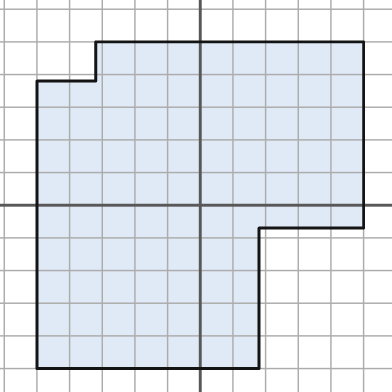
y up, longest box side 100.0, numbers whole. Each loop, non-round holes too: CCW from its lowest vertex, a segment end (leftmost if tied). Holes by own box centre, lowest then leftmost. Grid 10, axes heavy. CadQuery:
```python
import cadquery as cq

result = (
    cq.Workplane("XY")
    .moveTo(-50.0, -50.0)
    .lineTo(18.0, -50.0)
    .lineTo(18.0, -7.0)
    .lineTo(50.0, -7.0)
    .lineTo(50.0, 50.0)
    .lineTo(-32.0, 50.0)
    .lineTo(-32.0, 38.0)
    .lineTo(-50.0, 38.0)
    .close()
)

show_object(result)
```